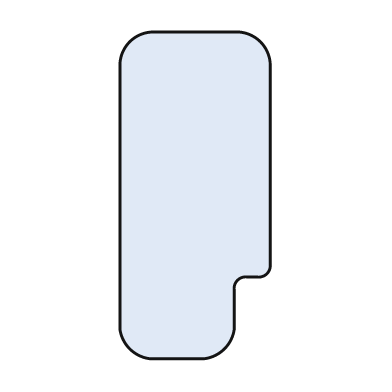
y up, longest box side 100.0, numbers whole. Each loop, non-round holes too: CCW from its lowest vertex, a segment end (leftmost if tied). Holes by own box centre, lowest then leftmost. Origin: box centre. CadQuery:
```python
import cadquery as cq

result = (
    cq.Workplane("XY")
    .moveTo(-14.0, -50.0)
    .lineTo(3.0, -50.0)
    .threePointArc((9.0, -47.0), (12.0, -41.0))
    .lineTo(12.0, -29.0)
    .threePointArc((13.0, -26.0), (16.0, -25.0))
    .lineTo(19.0, -25.0)
    .threePointArc((22.0, -24.0), (23.0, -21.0))
    .lineTo(23.0, 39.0)
    .threePointArc((20.0, 47.0), (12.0, 50.0))
    .lineTo(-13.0, 50.0)
    .threePointArc((-20.0, 47.0), (-23.0, 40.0))
    .lineTo(-23.0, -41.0)
    .threePointArc((-20.0, -47.0), (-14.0, -50.0))
    .close()
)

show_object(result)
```